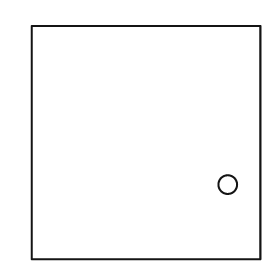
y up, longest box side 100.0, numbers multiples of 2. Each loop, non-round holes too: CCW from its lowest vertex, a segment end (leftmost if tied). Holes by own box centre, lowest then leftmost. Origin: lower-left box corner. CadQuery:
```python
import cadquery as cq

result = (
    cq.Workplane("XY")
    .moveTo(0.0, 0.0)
    .lineTo(98.0, 0.0)
    .lineTo(98.0, 100.0)
    .lineTo(0.0, 100.0)
    .close()
    .moveTo(84.0, 32.0)
    .circle(4.0)
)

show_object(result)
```